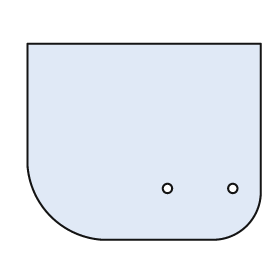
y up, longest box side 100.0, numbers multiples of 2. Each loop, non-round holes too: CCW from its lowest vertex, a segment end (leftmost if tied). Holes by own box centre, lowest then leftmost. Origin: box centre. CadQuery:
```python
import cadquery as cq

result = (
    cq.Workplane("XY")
    .moveTo(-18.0, -42.0)
    .lineTo(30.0, -42.0)
    .threePointArc((44.0, -36.0), (50.0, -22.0))
    .lineTo(50.0, 42.0)
    .lineTo(-50.0, 42.0)
    .lineTo(-50.0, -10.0)
    .threePointArc((-40.0, -32.0), (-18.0, -42.0))
    .close()
    .moveTo(10.0, -20.0)
    .circle(2.0)
    .moveTo(38.0, -20.0)
    .circle(2.0)
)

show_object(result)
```